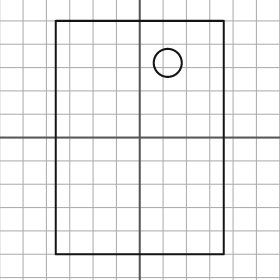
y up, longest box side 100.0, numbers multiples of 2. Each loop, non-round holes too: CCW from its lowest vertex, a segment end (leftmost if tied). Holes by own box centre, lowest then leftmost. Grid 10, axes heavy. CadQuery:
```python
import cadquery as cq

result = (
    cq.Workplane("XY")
    .moveTo(-36.0, -50.0)
    .lineTo(36.0, -50.0)
    .lineTo(36.0, 50.0)
    .lineTo(-36.0, 50.0)
    .close()
    .moveTo(12.0, 32.0)
    .circle(6.0)
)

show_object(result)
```